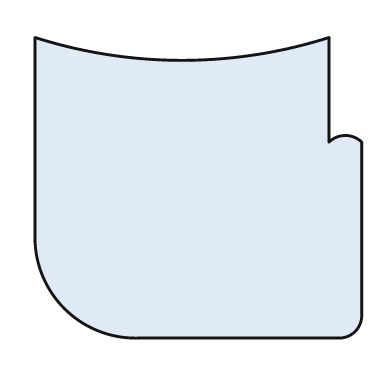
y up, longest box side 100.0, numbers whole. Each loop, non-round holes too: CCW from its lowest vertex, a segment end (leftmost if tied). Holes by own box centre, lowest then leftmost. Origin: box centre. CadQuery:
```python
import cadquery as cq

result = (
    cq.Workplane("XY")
    .moveTo(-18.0, -46.0)
    .lineTo(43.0, -46.0)
    .threePointArc((48.0, -44.0), (50.0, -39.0))
    .lineTo(50.0, 14.0)
    .threePointArc((45.0, 16.0), (40.0, 14.0))
    .lineTo(40.0, 46.0)
    .threePointArc((-5.0, 39.0), (-50.0, 46.0))
    .lineTo(-50.0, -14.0)
    .threePointArc((-41.0, -37.0), (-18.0, -46.0))
    .close()
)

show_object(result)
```